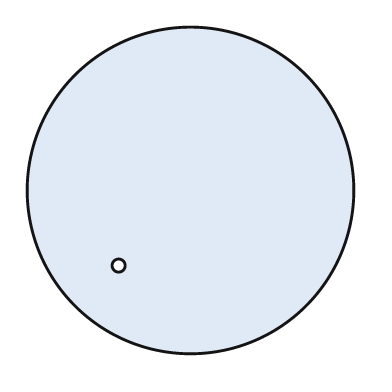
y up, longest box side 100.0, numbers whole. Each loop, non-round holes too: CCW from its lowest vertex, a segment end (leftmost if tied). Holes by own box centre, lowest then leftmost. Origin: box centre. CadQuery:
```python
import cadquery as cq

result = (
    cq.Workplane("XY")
    .moveTo(0.0, 0.0)
    .circle(50.0)
    .moveTo(-22.0, -23.0)
    .circle(2.0)
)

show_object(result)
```